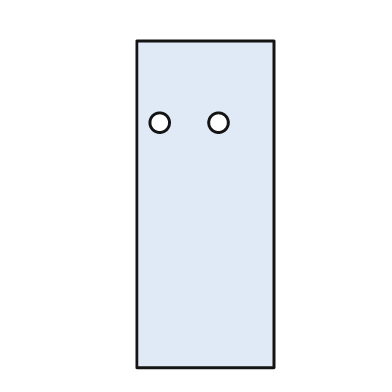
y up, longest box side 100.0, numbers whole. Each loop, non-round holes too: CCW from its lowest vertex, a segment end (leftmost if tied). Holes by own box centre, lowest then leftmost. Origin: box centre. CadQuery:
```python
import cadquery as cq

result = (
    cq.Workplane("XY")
    .moveTo(-21.0, -50.0)
    .lineTo(21.0, -50.0)
    .lineTo(21.0, 50.0)
    .lineTo(-21.0, 50.0)
    .close()
    .moveTo(-14.0, 25.0)
    .circle(3.0)
    .moveTo(4.0, 25.0)
    .circle(3.0)
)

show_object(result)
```